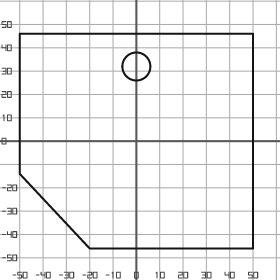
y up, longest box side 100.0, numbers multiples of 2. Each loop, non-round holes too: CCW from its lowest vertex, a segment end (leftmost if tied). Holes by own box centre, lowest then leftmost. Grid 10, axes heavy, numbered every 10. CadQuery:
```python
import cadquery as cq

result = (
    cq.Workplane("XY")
    .moveTo(-20.0, -46.0)
    .lineTo(50.0, -46.0)
    .lineTo(50.0, 46.0)
    .lineTo(-50.0, 46.0)
    .lineTo(-50.0, -14.0)
    .close()
    .moveTo(0.0, 32.0)
    .circle(6.0)
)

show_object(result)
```